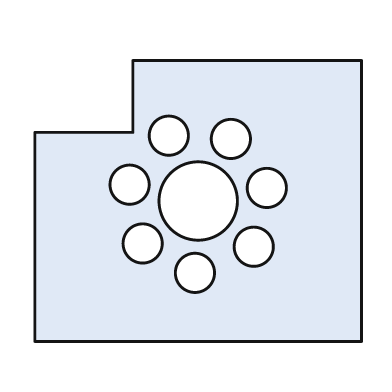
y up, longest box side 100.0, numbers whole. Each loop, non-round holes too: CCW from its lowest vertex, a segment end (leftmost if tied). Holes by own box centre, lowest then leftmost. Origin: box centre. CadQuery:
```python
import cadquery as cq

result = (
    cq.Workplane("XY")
    .moveTo(-50.0, -43.0)
    .lineTo(50.0, -43.0)
    .lineTo(50.0, 43.0)
    .lineTo(-20.0, 43.0)
    .lineTo(-20.0, 21.0)
    .lineTo(-50.0, 21.0)
    .close()
    .moveTo(-1.0, -22.0)
    .circle(6.0)
    .moveTo(17.0, -14.0)
    .circle(6.0)
    .moveTo(-17.0, -13.0)
    .circle(6.0)
    .moveTo(0.0, 0.0)
    .circle(12.0)
    .moveTo(21.0, 4.0)
    .circle(6.0)
    .moveTo(-21.0, 5.0)
    .circle(6.0)
    .moveTo(10.0, 19.0)
    .circle(6.0)
    .moveTo(-9.0, 20.0)
    .circle(6.0)
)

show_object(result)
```